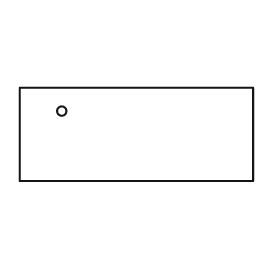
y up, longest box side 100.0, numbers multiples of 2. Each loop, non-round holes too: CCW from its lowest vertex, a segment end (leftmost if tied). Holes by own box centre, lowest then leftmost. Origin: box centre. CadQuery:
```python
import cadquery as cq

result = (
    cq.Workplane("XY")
    .moveTo(-50.0, -20.0)
    .lineTo(50.0, -20.0)
    .lineTo(50.0, 20.0)
    .lineTo(-50.0, 20.0)
    .close()
    .moveTo(-32.0, 10.0)
    .circle(2.0)
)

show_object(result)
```